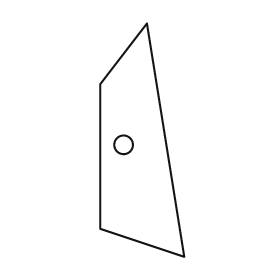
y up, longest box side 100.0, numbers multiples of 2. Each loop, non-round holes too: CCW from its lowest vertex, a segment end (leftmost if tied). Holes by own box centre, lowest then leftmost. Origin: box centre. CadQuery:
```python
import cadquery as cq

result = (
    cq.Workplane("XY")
    .moveTo(18.0, -50.0)
    .lineTo(2.0, 50.0)
    .lineTo(-18.0, 24.0)
    .lineTo(-18.0, -38.0)
    .close()
    .moveTo(-8.0, -2.0)
    .circle(4.0)
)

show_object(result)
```